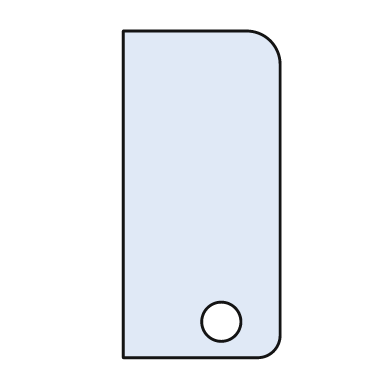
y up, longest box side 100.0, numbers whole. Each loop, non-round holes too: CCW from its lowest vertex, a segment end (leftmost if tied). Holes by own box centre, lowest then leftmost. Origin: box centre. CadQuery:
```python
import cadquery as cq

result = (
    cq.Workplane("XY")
    .moveTo(-24.0, -50.0)
    .lineTo(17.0, -50.0)
    .threePointArc((22.0, -48.0), (24.0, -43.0))
    .lineTo(24.0, 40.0)
    .threePointArc((21.0, 47.0), (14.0, 50.0))
    .lineTo(-24.0, 50.0)
    .close()
    .moveTo(6.0, -39.0)
    .circle(6.0)
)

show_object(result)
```